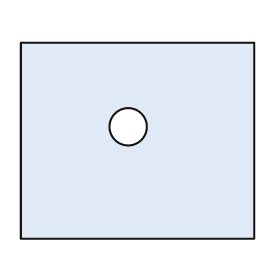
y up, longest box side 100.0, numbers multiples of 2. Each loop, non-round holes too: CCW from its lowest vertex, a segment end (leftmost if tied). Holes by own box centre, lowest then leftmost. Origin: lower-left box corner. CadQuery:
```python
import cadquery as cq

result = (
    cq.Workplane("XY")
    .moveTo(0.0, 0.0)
    .lineTo(100.0, 0.0)
    .lineTo(100.0, 84.0)
    .lineTo(0.0, 84.0)
    .close()
    .moveTo(46.0, 48.0)
    .circle(8.0)
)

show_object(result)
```